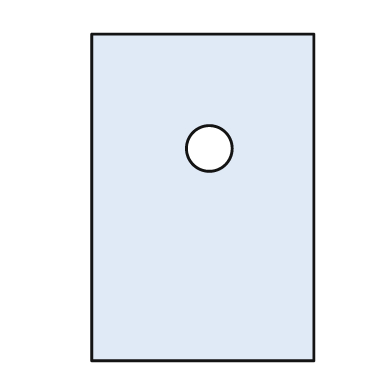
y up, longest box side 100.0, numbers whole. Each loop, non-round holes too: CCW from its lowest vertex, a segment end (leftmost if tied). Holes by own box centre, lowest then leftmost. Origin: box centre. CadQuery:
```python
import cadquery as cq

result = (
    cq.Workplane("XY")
    .moveTo(-34.0, -50.0)
    .lineTo(34.0, -50.0)
    .lineTo(34.0, 50.0)
    .lineTo(-34.0, 50.0)
    .close()
    .moveTo(2.0, 15.0)
    .circle(7.0)
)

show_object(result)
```